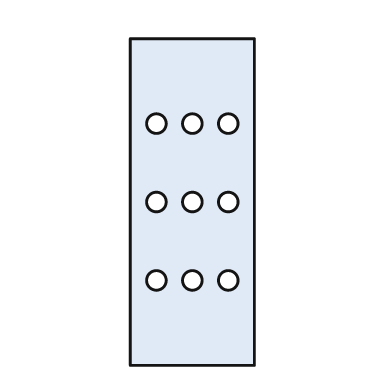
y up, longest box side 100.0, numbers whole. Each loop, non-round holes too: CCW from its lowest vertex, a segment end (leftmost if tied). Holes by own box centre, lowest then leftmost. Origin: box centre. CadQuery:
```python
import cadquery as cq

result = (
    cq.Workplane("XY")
    .moveTo(-19.0, -50.0)
    .lineTo(19.0, -50.0)
    .lineTo(19.0, 50.0)
    .lineTo(-19.0, 50.0)
    .close()
    .moveTo(-11.0, -24.0)
    .circle(3.0)
    .moveTo(0.0, -24.0)
    .circle(3.0)
    .moveTo(11.0, -24.0)
    .circle(3.0)
    .moveTo(-11.0, 0.0)
    .circle(3.0)
    .moveTo(0.0, 0.0)
    .circle(3.0)
    .moveTo(11.0, 0.0)
    .circle(3.0)
    .moveTo(-11.0, 24.0)
    .circle(3.0)
    .moveTo(0.0, 24.0)
    .circle(3.0)
    .moveTo(11.0, 24.0)
    .circle(3.0)
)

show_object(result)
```